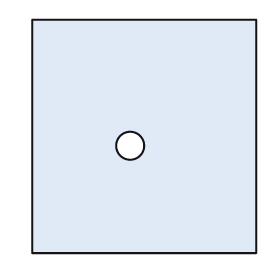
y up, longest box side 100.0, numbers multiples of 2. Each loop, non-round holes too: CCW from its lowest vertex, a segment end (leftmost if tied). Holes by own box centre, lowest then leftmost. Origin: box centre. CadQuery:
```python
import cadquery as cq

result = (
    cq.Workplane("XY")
    .moveTo(-48.0, -50.0)
    .lineTo(48.0, -50.0)
    .lineTo(48.0, 50.0)
    .lineTo(-48.0, 50.0)
    .close()
    .moveTo(-6.0, -4.0)
    .circle(6.0)
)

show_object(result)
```